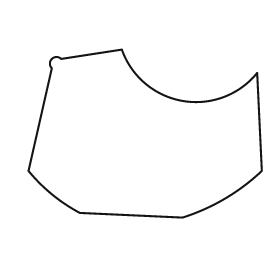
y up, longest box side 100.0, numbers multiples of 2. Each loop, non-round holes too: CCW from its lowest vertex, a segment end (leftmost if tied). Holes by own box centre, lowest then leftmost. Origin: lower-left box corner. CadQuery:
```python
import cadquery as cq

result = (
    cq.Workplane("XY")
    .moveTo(66.0, 0.0)
    .threePointArc((84.0, 8.0), (100.0, 20.0))
    .lineTo(98.0, 62.0)
    .threePointArc((66.0, 50.0), (40.0, 72.0))
    .lineTo(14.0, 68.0)
    .threePointArc((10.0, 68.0), (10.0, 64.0))
    .lineTo(0.0, 20.0)
    .threePointArc((10.0, 10.0), (22.0, 2.0))
    .close()
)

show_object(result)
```